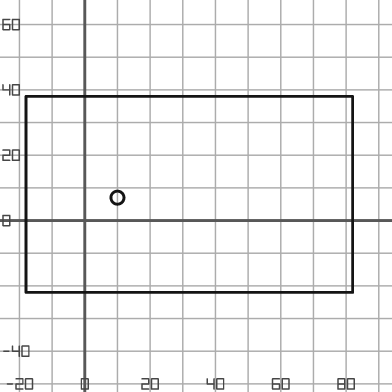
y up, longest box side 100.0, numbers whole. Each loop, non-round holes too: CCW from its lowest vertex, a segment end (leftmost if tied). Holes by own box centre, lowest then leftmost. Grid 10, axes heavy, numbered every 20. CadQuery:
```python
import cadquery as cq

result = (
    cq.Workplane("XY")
    .moveTo(-18.0, -22.0)
    .lineTo(82.0, -22.0)
    .lineTo(82.0, 38.0)
    .lineTo(-18.0, 38.0)
    .close()
    .moveTo(10.0, 7.0)
    .circle(2.0)
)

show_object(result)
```